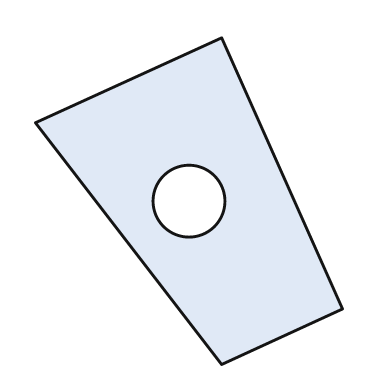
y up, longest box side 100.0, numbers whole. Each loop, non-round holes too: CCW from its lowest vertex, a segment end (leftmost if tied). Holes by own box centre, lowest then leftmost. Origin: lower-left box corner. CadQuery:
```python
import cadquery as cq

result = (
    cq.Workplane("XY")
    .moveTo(57.0, 0.0)
    .lineTo(94.0, 17.0)
    .lineTo(57.0, 100.0)
    .lineTo(0.0, 74.0)
    .close()
    .moveTo(47.0, 50.0)
    .circle(11.0)
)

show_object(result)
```